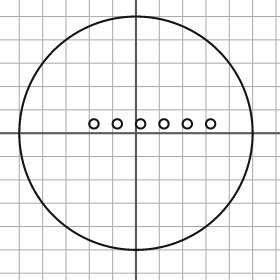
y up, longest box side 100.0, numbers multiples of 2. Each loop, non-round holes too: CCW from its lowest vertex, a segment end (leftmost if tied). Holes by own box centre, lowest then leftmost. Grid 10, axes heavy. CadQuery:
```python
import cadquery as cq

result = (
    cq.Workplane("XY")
    .moveTo(0.0, 0.0)
    .circle(50.0)
    .moveTo(-18.0, 4.0)
    .circle(2.0)
    .moveTo(-8.0, 4.0)
    .circle(2.0)
    .moveTo(2.0, 4.0)
    .circle(2.0)
    .moveTo(12.0, 4.0)
    .circle(2.0)
    .moveTo(22.0, 4.0)
    .circle(2.0)
    .moveTo(32.0, 4.0)
    .circle(2.0)
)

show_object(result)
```